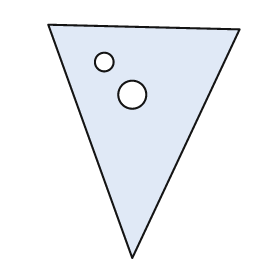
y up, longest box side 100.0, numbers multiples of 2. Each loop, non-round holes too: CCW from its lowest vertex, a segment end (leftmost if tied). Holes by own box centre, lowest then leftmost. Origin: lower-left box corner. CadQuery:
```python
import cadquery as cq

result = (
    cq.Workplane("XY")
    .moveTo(36.0, 0.0)
    .lineTo(82.0, 98.0)
    .lineTo(0.0, 100.0)
    .close()
    .moveTo(36.0, 70.0)
    .circle(6.0)
    .moveTo(24.0, 84.0)
    .circle(4.0)
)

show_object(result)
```